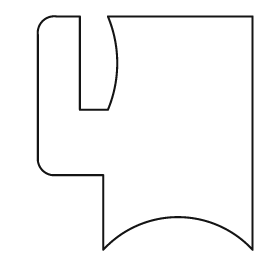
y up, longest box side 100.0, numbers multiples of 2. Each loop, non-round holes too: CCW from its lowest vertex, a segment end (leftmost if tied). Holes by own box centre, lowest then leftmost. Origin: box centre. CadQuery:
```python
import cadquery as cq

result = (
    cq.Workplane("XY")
    .moveTo(-18.0, -50.0)
    .threePointArc((14.0, -36.0), (46.0, -50.0))
    .lineTo(46.0, 50.0)
    .lineTo(-16.0, 50.0)
    .threePointArc((-12.0, 30.0), (-16.0, 10.0))
    .lineTo(-28.0, 10.0)
    .lineTo(-28.0, 50.0)
    .lineTo(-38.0, 50.0)
    .threePointArc((-44.0, 48.0), (-46.0, 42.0))
    .lineTo(-46.0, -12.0)
    .threePointArc((-44.0, -16.0), (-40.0, -18.0))
    .lineTo(-18.0, -18.0)
    .close()
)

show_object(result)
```